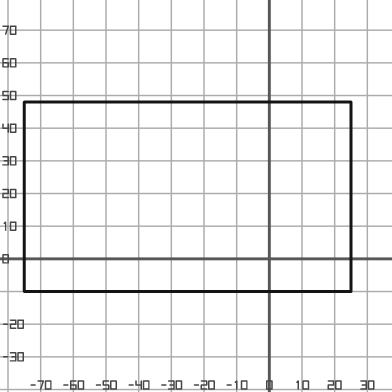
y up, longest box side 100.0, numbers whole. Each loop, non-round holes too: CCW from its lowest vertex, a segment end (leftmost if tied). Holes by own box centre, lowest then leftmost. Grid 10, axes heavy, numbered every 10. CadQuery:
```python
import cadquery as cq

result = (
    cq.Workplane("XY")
    .moveTo(-75.0, -10.0)
    .lineTo(25.0, -10.0)
    .lineTo(25.0, 48.0)
    .lineTo(-75.0, 48.0)
    .close()
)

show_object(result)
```